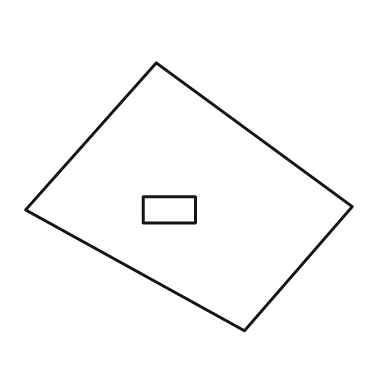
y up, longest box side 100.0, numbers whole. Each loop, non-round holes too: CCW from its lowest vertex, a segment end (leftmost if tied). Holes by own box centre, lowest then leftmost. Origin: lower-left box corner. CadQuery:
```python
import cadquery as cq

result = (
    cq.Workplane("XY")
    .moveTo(67.0, 0.0)
    .lineTo(100.0, 38.0)
    .lineTo(40.0, 82.0)
    .lineTo(0.0, 37.0)
    .close()
    .moveTo(36.0, 33.0)
    .lineTo(52.0, 33.0)
    .lineTo(52.0, 41.0)
    .lineTo(36.0, 41.0)
    .close()
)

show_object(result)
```